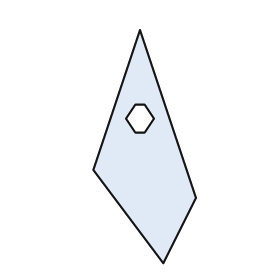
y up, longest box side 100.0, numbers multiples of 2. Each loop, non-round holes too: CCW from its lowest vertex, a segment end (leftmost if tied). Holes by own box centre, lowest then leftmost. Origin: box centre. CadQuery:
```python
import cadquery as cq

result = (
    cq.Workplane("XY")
    .moveTo(8.0, -50.0)
    .lineTo(22.0, -22.0)
    .lineTo(-2.0, 50.0)
    .lineTo(-22.0, -10.0)
    .close()
    .moveTo(-4.0, 6.0)
    .lineTo(0.0, 6.0)
    .lineTo(4.0, 12.0)
    .lineTo(0.0, 18.0)
    .lineTo(-4.0, 18.0)
    .lineTo(-8.0, 12.0)
    .close()
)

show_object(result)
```